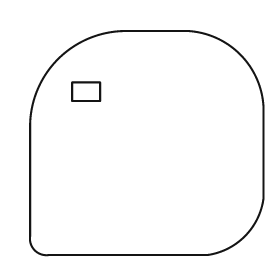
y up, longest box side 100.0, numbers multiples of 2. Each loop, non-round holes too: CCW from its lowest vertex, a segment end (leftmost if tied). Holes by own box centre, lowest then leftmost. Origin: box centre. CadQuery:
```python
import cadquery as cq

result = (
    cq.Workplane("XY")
    .moveTo(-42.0, -48.0)
    .lineTo(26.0, -48.0)
    .threePointArc((42.0, -40.0), (50.0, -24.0))
    .lineTo(50.0, 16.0)
    .threePointArc((40.0, 38.0), (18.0, 48.0))
    .lineTo(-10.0, 48.0)
    .threePointArc((-38.0, 36.0), (-50.0, 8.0))
    .lineTo(-50.0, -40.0)
    .threePointArc((-48.0, -46.0), (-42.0, -48.0))
    .close()
    .moveTo(-32.0, 18.0)
    .lineTo(-20.0, 18.0)
    .lineTo(-20.0, 26.0)
    .lineTo(-32.0, 26.0)
    .close()
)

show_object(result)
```